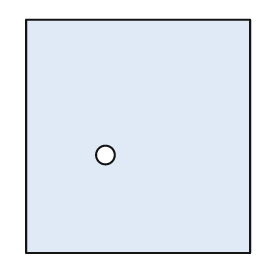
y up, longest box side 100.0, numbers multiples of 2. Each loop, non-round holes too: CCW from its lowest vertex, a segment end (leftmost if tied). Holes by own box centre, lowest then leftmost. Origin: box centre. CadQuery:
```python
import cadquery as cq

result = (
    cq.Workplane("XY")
    .moveTo(-48.0, -50.0)
    .lineTo(48.0, -50.0)
    .lineTo(48.0, 50.0)
    .lineTo(-48.0, 50.0)
    .close()
    .moveTo(-14.0, -8.0)
    .circle(4.0)
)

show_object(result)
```